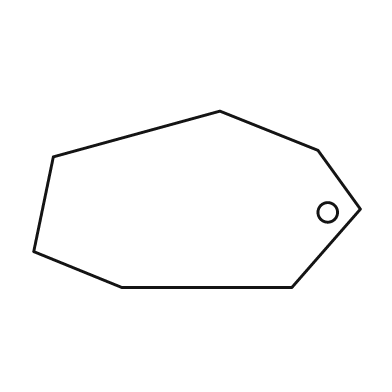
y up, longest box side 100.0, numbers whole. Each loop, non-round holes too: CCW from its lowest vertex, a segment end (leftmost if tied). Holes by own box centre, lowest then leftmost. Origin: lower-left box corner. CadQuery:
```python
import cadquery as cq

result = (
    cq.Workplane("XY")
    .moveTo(27.0, 0.0)
    .lineTo(79.0, 0.0)
    .lineTo(100.0, 24.0)
    .lineTo(87.0, 42.0)
    .lineTo(57.0, 54.0)
    .lineTo(6.0, 40.0)
    .lineTo(0.0, 11.0)
    .close()
    .moveTo(90.0, 23.0)
    .circle(3.0)
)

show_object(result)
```